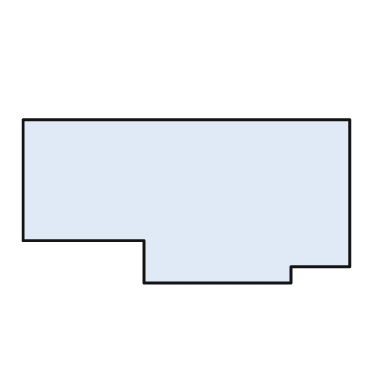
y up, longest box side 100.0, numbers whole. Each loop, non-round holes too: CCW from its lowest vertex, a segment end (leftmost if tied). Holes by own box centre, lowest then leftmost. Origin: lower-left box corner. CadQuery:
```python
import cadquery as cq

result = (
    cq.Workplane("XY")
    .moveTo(37.0, 0.0)
    .lineTo(82.0, 0.0)
    .lineTo(82.0, 5.0)
    .lineTo(100.0, 5.0)
    .lineTo(100.0, 50.0)
    .lineTo(0.0, 50.0)
    .lineTo(0.0, 13.0)
    .lineTo(37.0, 13.0)
    .close()
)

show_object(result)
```